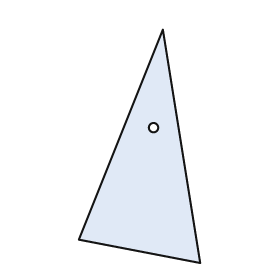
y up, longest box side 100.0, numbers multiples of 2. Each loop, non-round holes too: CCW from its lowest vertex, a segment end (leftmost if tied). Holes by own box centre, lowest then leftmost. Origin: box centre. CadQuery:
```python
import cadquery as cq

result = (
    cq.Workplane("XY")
    .moveTo(26.0, -50.0)
    .lineTo(10.0, 50.0)
    .lineTo(-26.0, -40.0)
    .close()
    .moveTo(6.0, 8.0)
    .circle(2.0)
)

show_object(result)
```